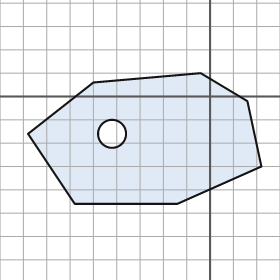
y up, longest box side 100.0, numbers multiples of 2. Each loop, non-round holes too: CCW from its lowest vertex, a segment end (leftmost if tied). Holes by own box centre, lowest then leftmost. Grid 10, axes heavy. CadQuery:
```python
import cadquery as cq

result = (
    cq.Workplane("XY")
    .moveTo(-58.0, -46.0)
    .lineTo(-14.0, -46.0)
    .lineTo(22.0, -30.0)
    .lineTo(16.0, -2.0)
    .lineTo(-4.0, 10.0)
    .lineTo(-50.0, 6.0)
    .lineTo(-78.0, -16.0)
    .close()
    .moveTo(-42.0, -16.0)
    .circle(6.0)
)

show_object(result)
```